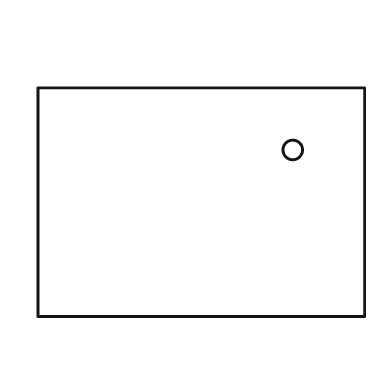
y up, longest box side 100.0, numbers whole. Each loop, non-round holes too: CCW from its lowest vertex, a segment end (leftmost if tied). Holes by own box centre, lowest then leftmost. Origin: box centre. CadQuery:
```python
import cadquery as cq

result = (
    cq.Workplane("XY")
    .moveTo(-50.0, -35.0)
    .lineTo(50.0, -35.0)
    .lineTo(50.0, 35.0)
    .lineTo(-50.0, 35.0)
    .close()
    .moveTo(28.0, 16.0)
    .circle(3.0)
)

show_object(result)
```